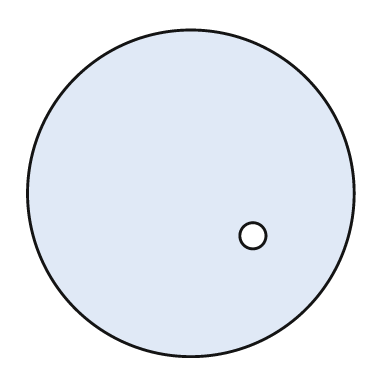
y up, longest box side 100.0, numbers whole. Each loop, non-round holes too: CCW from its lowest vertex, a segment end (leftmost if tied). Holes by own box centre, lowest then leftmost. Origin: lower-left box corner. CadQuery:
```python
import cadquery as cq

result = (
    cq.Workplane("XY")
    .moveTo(50.0, 50.0)
    .circle(50.0)
    .moveTo(69.0, 37.0)
    .circle(4.0)
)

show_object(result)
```